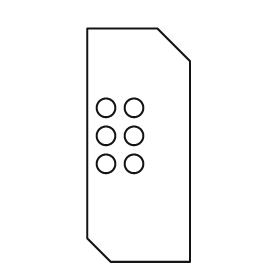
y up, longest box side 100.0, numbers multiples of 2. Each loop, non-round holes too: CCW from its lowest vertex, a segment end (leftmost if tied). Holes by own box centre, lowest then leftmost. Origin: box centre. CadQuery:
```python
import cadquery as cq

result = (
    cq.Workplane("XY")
    .moveTo(-12.0, -50.0)
    .lineTo(22.0, -50.0)
    .lineTo(22.0, 36.0)
    .lineTo(8.0, 50.0)
    .lineTo(-22.0, 50.0)
    .lineTo(-22.0, -40.0)
    .close()
    .moveTo(-14.0, -8.0)
    .circle(4.0)
    .moveTo(-2.0, -8.0)
    .circle(4.0)
    .moveTo(-14.0, 4.0)
    .circle(4.0)
    .moveTo(-2.0, 4.0)
    .circle(4.0)
    .moveTo(-14.0, 16.0)
    .circle(4.0)
    .moveTo(-2.0, 16.0)
    .circle(4.0)
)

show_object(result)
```